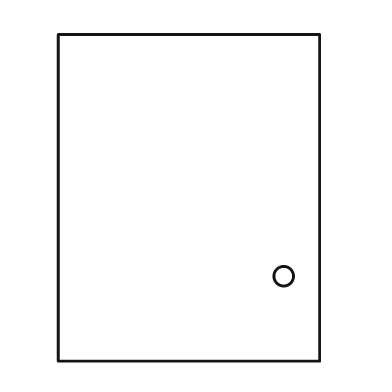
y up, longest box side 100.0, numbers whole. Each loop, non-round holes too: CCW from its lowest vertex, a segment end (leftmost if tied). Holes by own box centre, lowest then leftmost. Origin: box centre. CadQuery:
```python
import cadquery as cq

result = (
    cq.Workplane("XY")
    .moveTo(-40.0, -50.0)
    .lineTo(40.0, -50.0)
    .lineTo(40.0, 50.0)
    .lineTo(-40.0, 50.0)
    .close()
    .moveTo(29.0, -24.0)
    .circle(3.0)
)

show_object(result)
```